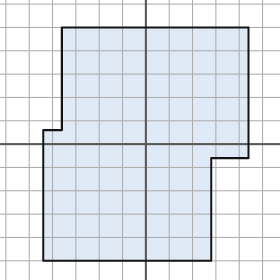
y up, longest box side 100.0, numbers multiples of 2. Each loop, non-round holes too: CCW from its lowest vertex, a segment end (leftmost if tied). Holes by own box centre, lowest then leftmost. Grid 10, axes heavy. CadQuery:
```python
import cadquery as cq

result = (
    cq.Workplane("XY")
    .moveTo(-44.0, -50.0)
    .lineTo(28.0, -50.0)
    .lineTo(28.0, -6.0)
    .lineTo(44.0, -6.0)
    .lineTo(44.0, 50.0)
    .lineTo(-36.0, 50.0)
    .lineTo(-36.0, 6.0)
    .lineTo(-44.0, 6.0)
    .close()
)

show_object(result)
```